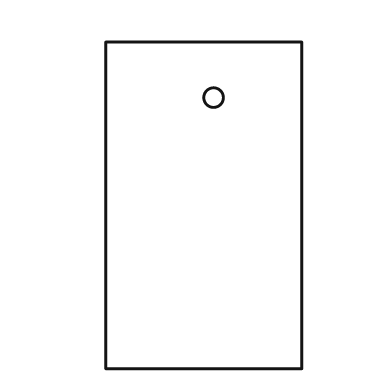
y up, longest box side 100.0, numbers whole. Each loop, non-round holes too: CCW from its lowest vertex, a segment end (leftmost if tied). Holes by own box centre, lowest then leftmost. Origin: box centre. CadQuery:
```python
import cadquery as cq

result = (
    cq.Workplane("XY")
    .moveTo(-30.0, -50.0)
    .lineTo(30.0, -50.0)
    .lineTo(30.0, 50.0)
    .lineTo(-30.0, 50.0)
    .close()
    .moveTo(3.0, 33.0)
    .circle(3.0)
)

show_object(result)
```